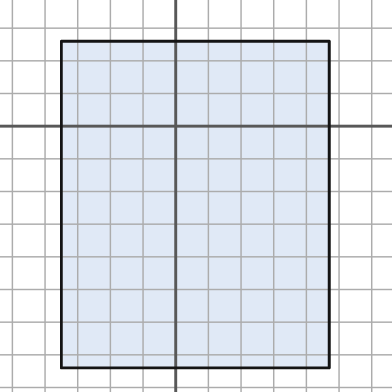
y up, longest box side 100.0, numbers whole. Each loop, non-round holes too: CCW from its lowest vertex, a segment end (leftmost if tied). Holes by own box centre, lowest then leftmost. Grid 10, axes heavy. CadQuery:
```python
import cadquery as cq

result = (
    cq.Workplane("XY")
    .moveTo(-35.0, -74.0)
    .lineTo(47.0, -74.0)
    .lineTo(47.0, 26.0)
    .lineTo(-35.0, 26.0)
    .close()
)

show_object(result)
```